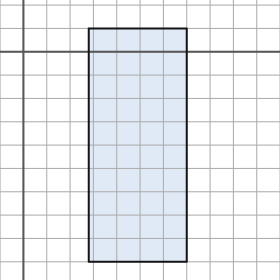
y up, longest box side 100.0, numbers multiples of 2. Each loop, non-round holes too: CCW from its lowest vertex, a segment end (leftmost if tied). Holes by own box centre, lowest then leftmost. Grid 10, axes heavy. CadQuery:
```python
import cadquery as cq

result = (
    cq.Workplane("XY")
    .moveTo(28.0, -90.0)
    .lineTo(70.0, -90.0)
    .lineTo(70.0, 10.0)
    .lineTo(28.0, 10.0)
    .close()
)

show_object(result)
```